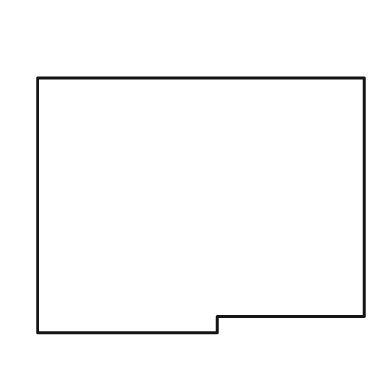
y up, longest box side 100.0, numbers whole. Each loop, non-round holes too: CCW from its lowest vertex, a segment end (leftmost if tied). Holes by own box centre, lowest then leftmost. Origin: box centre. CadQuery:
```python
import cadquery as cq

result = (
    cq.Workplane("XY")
    .moveTo(-50.0, -39.0)
    .lineTo(5.0, -39.0)
    .lineTo(5.0, -34.0)
    .lineTo(50.0, -34.0)
    .lineTo(50.0, 39.0)
    .lineTo(-50.0, 39.0)
    .close()
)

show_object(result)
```